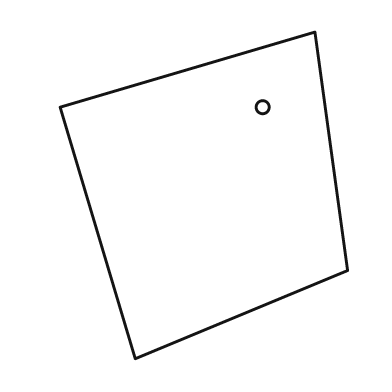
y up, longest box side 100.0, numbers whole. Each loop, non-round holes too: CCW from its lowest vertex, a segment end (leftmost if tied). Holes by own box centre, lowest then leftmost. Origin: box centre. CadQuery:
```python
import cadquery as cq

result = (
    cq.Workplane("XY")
    .moveTo(-21.0, -50.0)
    .lineTo(44.0, -23.0)
    .lineTo(34.0, 50.0)
    .lineTo(-44.0, 27.0)
    .close()
    .moveTo(18.0, 27.0)
    .circle(2.0)
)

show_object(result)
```